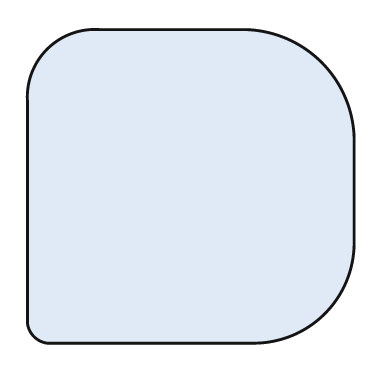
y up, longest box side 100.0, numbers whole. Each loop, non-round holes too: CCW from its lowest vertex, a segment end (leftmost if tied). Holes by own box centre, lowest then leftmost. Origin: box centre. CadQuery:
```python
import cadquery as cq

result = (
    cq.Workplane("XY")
    .moveTo(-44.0, -48.0)
    .lineTo(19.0, -48.0)
    .threePointArc((41.0, -39.0), (50.0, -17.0))
    .lineTo(50.0, 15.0)
    .threePointArc((40.0, 38.0), (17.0, 48.0))
    .lineTo(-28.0, 48.0)
    .threePointArc((-44.0, 42.0), (-50.0, 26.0))
    .lineTo(-50.0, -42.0)
    .threePointArc((-48.0, -46.0), (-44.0, -48.0))
    .close()
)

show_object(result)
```